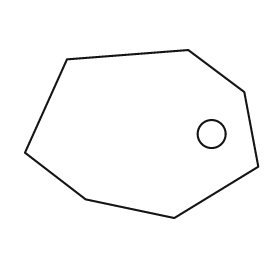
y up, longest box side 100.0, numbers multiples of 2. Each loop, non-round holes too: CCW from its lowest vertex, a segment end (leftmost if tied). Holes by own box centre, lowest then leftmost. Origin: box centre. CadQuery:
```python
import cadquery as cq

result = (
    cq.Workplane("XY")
    .moveTo(14.0, -36.0)
    .lineTo(50.0, -14.0)
    .lineTo(44.0, 18.0)
    .lineTo(20.0, 36.0)
    .lineTo(-32.0, 32.0)
    .lineTo(-50.0, -8.0)
    .lineTo(-24.0, -28.0)
    .close()
    .moveTo(30.0, 0.0)
    .circle(6.0)
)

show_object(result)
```